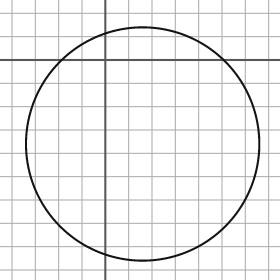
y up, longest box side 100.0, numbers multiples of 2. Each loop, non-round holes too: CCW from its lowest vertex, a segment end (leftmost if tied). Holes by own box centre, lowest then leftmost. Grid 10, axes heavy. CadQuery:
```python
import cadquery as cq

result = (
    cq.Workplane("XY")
    .moveTo(16.0, -36.0)
    .circle(50.0)
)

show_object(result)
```